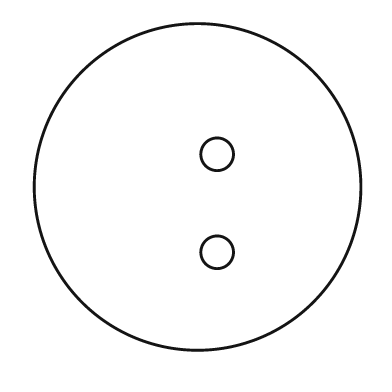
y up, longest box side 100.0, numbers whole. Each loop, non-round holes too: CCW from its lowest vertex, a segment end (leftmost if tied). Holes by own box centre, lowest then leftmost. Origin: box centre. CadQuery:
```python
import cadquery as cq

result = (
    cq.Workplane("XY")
    .moveTo(0.0, 0.0)
    .circle(50.0)
    .moveTo(6.0, -20.0)
    .circle(5.0)
    .moveTo(6.0, 10.0)
    .circle(5.0)
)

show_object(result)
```